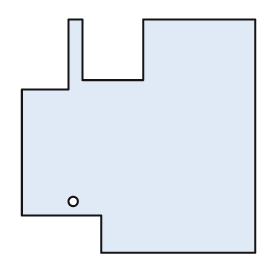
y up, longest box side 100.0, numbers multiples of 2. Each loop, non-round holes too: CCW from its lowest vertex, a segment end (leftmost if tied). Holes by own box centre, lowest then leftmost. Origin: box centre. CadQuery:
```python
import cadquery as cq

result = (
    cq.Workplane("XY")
    .moveTo(-16.0, -50.0)
    .lineTo(50.0, -50.0)
    .lineTo(50.0, 50.0)
    .lineTo(2.0, 50.0)
    .lineTo(2.0, 24.0)
    .lineTo(-24.0, 24.0)
    .lineTo(-24.0, 50.0)
    .lineTo(-30.0, 50.0)
    .lineTo(-30.0, 20.0)
    .lineTo(-50.0, 20.0)
    .lineTo(-50.0, -34.0)
    .lineTo(-16.0, -34.0)
    .close()
    .moveTo(-28.0, -28.0)
    .circle(2.0)
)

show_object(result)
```